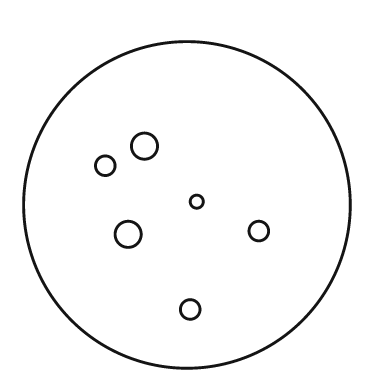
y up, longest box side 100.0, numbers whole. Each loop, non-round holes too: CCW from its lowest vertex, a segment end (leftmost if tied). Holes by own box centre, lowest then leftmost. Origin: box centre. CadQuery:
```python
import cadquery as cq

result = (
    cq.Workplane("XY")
    .moveTo(0.0, 0.0)
    .circle(50.0)
    .moveTo(1.0, -32.0)
    .circle(3.0)
    .moveTo(-18.0, -9.0)
    .circle(4.0)
    .moveTo(22.0, -8.0)
    .circle(3.0)
    .moveTo(3.0, 1.0)
    .circle(2.0)
    .moveTo(-25.0, 12.0)
    .circle(3.0)
    .moveTo(-13.0, 18.0)
    .circle(4.0)
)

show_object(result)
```